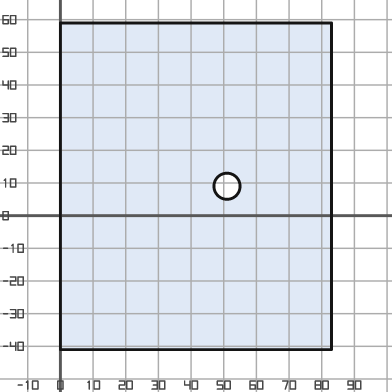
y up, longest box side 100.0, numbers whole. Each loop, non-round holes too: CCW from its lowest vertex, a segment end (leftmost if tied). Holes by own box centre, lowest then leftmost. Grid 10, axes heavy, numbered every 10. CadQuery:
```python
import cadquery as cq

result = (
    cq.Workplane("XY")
    .moveTo(0.0, -41.0)
    .lineTo(83.0, -41.0)
    .lineTo(83.0, 59.0)
    .lineTo(0.0, 59.0)
    .close()
    .moveTo(51.0, 9.0)
    .circle(4.0)
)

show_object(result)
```